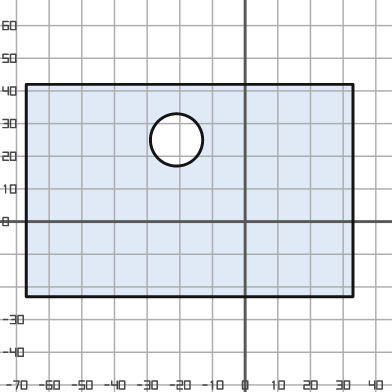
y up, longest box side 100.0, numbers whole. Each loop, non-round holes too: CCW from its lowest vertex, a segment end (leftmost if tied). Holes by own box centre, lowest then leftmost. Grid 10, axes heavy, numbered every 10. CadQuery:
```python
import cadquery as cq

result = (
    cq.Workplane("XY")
    .moveTo(-67.0, -23.0)
    .lineTo(33.0, -23.0)
    .lineTo(33.0, 42.0)
    .lineTo(-67.0, 42.0)
    .close()
    .moveTo(-21.0, 25.0)
    .circle(8.0)
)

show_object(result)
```